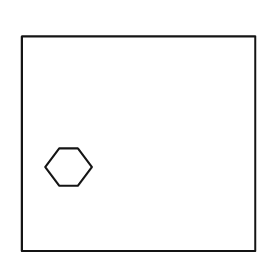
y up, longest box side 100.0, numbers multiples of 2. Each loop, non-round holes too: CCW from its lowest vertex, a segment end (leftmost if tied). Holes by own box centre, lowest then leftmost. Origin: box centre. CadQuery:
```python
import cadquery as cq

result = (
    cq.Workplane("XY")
    .moveTo(-50.0, -46.0)
    .lineTo(50.0, -46.0)
    .lineTo(50.0, 46.0)
    .lineTo(-50.0, 46.0)
    .close()
    .moveTo(-34.0, -18.0)
    .lineTo(-26.0, -18.0)
    .lineTo(-20.0, -10.0)
    .lineTo(-26.0, -2.0)
    .lineTo(-34.0, -2.0)
    .lineTo(-40.0, -10.0)
    .close()
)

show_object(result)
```